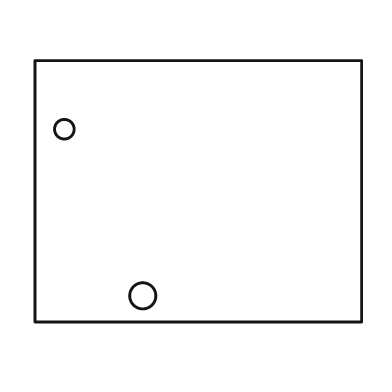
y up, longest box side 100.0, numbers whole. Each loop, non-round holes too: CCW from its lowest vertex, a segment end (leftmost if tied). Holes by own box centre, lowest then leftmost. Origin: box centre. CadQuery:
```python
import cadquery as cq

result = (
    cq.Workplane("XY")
    .moveTo(-50.0, -40.0)
    .lineTo(50.0, -40.0)
    .lineTo(50.0, 40.0)
    .lineTo(-50.0, 40.0)
    .close()
    .moveTo(-17.0, -32.0)
    .circle(4.0)
    .moveTo(-41.0, 19.0)
    .circle(3.0)
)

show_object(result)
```